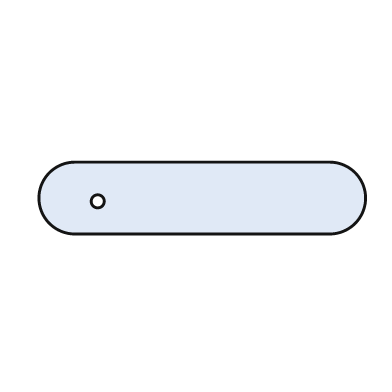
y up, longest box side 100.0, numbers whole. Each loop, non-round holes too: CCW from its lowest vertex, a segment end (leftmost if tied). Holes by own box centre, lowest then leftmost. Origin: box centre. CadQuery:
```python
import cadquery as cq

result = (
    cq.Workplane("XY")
    .moveTo(-39.0, -11.0)
    .lineTo(39.0, -11.0)
    .threePointArc((50.0, 0.0), (39.0, 11.0))
    .lineTo(-39.0, 11.0)
    .threePointArc((-50.0, 0.0), (-39.0, -11.0))
    .close()
    .moveTo(-32.0, -1.0)
    .circle(2.0)
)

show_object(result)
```